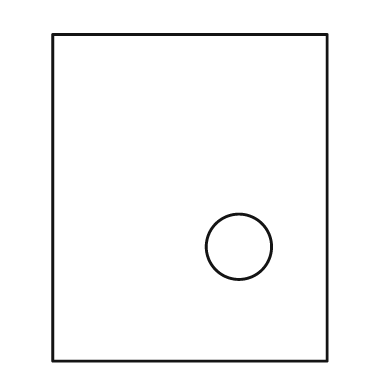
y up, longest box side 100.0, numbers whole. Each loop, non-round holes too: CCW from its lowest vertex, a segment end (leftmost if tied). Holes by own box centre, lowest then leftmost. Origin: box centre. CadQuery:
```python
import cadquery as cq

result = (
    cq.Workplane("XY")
    .moveTo(-42.0, -50.0)
    .lineTo(42.0, -50.0)
    .lineTo(42.0, 50.0)
    .lineTo(-42.0, 50.0)
    .close()
    .moveTo(15.0, -15.0)
    .circle(10.0)
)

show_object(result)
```